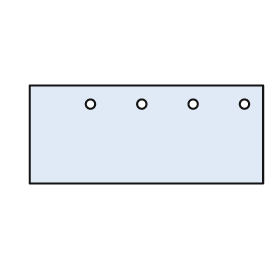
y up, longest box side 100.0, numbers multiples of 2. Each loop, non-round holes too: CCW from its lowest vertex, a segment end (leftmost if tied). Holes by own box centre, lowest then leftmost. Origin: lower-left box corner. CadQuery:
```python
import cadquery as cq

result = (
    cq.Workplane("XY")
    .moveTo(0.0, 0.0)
    .lineTo(100.0, 0.0)
    .lineTo(100.0, 42.0)
    .lineTo(0.0, 42.0)
    .close()
    .moveTo(26.0, 34.0)
    .circle(2.0)
    .moveTo(48.0, 34.0)
    .circle(2.0)
    .moveTo(70.0, 34.0)
    .circle(2.0)
    .moveTo(92.0, 34.0)
    .circle(2.0)
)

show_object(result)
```